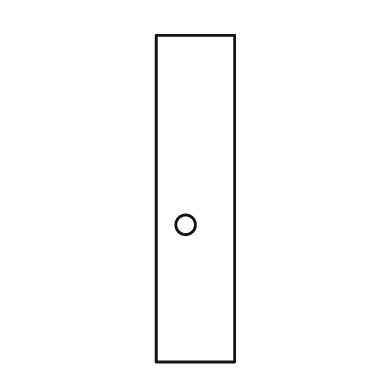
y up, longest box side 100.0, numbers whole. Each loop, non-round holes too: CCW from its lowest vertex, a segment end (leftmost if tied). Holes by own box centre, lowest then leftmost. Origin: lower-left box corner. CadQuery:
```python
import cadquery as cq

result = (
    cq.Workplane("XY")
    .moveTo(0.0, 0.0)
    .lineTo(24.0, 0.0)
    .lineTo(24.0, 100.0)
    .lineTo(0.0, 100.0)
    .close()
    .moveTo(9.0, 42.0)
    .circle(3.0)
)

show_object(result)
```